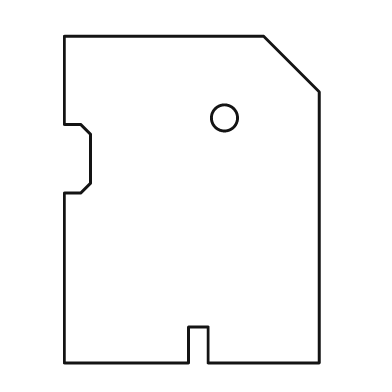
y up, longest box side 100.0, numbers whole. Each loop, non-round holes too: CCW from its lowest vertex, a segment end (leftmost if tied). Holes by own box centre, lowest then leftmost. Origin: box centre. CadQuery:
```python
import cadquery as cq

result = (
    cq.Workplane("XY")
    .moveTo(-39.0, -50.0)
    .lineTo(-1.0, -50.0)
    .lineTo(-1.0, -39.0)
    .lineTo(5.0, -39.0)
    .lineTo(5.0, -50.0)
    .lineTo(39.0, -50.0)
    .lineTo(39.0, 33.0)
    .lineTo(22.0, 50.0)
    .lineTo(-39.0, 50.0)
    .lineTo(-39.0, 23.0)
    .lineTo(-34.0, 23.0)
    .lineTo(-31.0, 20.0)
    .lineTo(-31.0, 5.0)
    .lineTo(-34.0, 2.0)
    .lineTo(-39.0, 2.0)
    .close()
    .moveTo(10.0, 25.0)
    .circle(4.0)
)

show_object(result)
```